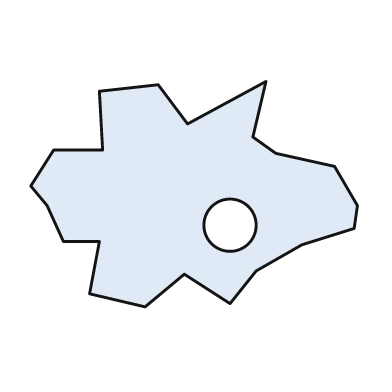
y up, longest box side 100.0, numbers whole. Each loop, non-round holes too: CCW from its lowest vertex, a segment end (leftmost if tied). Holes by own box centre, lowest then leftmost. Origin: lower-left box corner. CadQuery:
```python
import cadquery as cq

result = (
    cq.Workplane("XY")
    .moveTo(35.0, 0.0)
    .lineTo(47.0, 10.0)
    .lineTo(61.0, 1.0)
    .lineTo(69.0, 11.0)
    .lineTo(83.0, 19.0)
    .lineTo(99.0, 24.0)
    .lineTo(100.0, 31.0)
    .lineTo(93.0, 43.0)
    .lineTo(75.0, 47.0)
    .lineTo(68.0, 52.0)
    .lineTo(72.0, 69.0)
    .lineTo(48.0, 56.0)
    .lineTo(39.0, 68.0)
    .lineTo(21.0, 66.0)
    .lineTo(22.0, 48.0)
    .lineTo(7.0, 48.0)
    .lineTo(0.0, 37.0)
    .lineTo(5.0, 31.0)
    .lineTo(10.0, 20.0)
    .lineTo(21.0, 20.0)
    .lineTo(18.0, 4.0)
    .close()
    .moveTo(61.0, 25.0)
    .circle(8.0)
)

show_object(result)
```